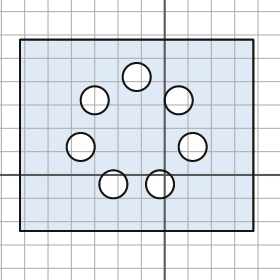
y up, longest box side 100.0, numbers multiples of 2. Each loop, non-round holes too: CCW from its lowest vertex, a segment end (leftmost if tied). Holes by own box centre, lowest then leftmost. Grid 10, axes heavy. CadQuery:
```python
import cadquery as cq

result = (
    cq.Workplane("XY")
    .moveTo(-62.0, -24.0)
    .lineTo(38.0, -24.0)
    .lineTo(38.0, 58.0)
    .lineTo(-62.0, 58.0)
    .close()
    .moveTo(-22.0, -4.0)
    .circle(6.0)
    .moveTo(-2.0, -4.0)
    .circle(6.0)
    .moveTo(-36.0, 12.0)
    .circle(6.0)
    .moveTo(12.0, 12.0)
    .circle(6.0)
    .moveTo(-30.0, 32.0)
    .circle(6.0)
    .moveTo(6.0, 32.0)
    .circle(6.0)
    .moveTo(-12.0, 42.0)
    .circle(6.0)
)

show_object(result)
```